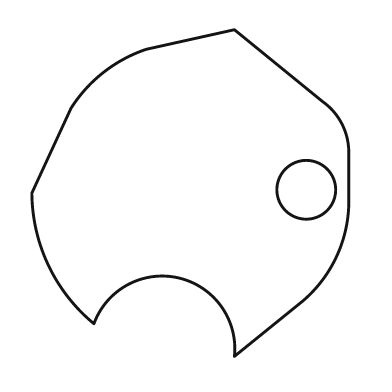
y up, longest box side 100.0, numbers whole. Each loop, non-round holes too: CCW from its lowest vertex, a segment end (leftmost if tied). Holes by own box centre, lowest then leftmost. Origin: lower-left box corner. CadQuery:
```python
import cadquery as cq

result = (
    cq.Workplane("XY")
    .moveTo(62.0, 0.0)
    .lineTo(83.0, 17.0)
    .threePointArc((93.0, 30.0), (97.0, 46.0))
    .lineTo(97.0, 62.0)
    .threePointArc((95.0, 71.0), (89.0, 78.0))
    .lineTo(62.0, 100.0)
    .lineTo(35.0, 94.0)
    .threePointArc((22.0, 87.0), (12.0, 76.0))
    .lineTo(0.0, 50.0)
    .threePointArc((5.0, 28.0), (19.0, 10.0))
    .threePointArc((45.0, 24.0), (62.0, 0.0))
    .close()
    .moveTo(84.0, 51.0)
    .circle(9.0)
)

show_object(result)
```